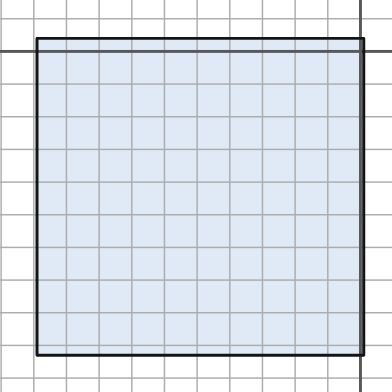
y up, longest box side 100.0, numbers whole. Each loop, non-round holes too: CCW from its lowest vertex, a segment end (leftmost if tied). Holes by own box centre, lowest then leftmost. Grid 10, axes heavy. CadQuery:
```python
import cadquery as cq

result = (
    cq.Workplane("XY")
    .moveTo(-99.0, -93.0)
    .lineTo(1.0, -93.0)
    .lineTo(1.0, 4.0)
    .lineTo(-99.0, 4.0)
    .close()
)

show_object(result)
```